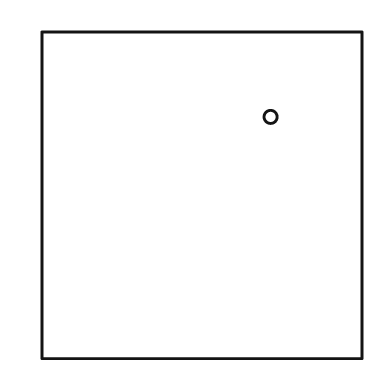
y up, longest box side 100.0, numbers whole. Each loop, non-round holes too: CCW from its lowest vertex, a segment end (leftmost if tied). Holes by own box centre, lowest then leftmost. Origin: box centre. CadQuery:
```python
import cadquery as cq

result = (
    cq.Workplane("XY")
    .moveTo(-49.0, -50.0)
    .lineTo(49.0, -50.0)
    .lineTo(49.0, 50.0)
    .lineTo(-49.0, 50.0)
    .close()
    .moveTo(21.0, 24.0)
    .circle(2.0)
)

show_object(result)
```